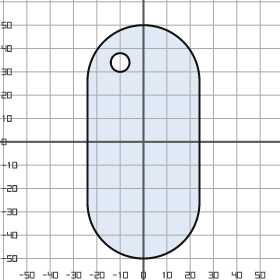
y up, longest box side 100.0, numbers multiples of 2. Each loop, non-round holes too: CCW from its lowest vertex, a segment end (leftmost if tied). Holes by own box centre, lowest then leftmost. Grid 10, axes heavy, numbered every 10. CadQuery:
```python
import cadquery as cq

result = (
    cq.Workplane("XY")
    .moveTo(-24.0, -26.0)
    .threePointArc((0.0, -50.0), (24.0, -26.0))
    .lineTo(24.0, 26.0)
    .threePointArc((0.0, 50.0), (-24.0, 26.0))
    .close()
    .moveTo(-10.0, 34.0)
    .circle(4.0)
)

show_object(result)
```